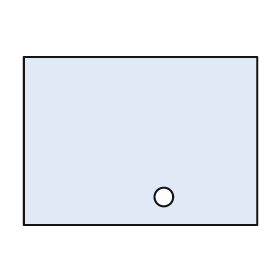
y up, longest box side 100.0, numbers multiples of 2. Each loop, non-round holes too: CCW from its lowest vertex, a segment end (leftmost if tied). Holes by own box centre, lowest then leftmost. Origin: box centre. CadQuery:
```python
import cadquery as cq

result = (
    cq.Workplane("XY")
    .moveTo(-50.0, -36.0)
    .lineTo(50.0, -36.0)
    .lineTo(50.0, 36.0)
    .lineTo(-50.0, 36.0)
    .close()
    .moveTo(10.0, -24.0)
    .circle(4.0)
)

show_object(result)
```